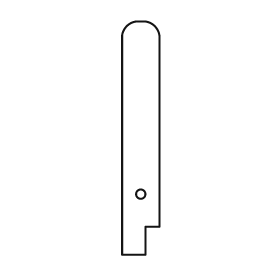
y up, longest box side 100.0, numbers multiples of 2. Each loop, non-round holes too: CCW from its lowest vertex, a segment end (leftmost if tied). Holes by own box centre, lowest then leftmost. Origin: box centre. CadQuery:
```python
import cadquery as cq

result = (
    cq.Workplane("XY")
    .moveTo(-8.0, -50.0)
    .lineTo(2.0, -50.0)
    .lineTo(2.0, -38.0)
    .lineTo(8.0, -38.0)
    .lineTo(8.0, 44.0)
    .threePointArc((6.0, 48.0), (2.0, 50.0))
    .lineTo(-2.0, 50.0)
    .threePointArc((-6.0, 48.0), (-8.0, 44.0))
    .close()
    .moveTo(0.0, -24.0)
    .circle(2.0)
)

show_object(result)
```